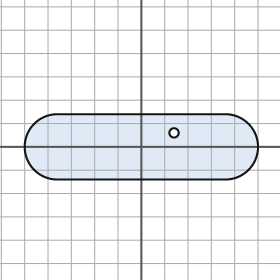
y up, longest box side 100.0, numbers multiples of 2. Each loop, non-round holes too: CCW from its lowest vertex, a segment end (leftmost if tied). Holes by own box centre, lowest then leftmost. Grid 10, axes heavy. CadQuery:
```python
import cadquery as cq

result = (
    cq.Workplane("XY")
    .moveTo(-36.0, -14.0)
    .lineTo(36.0, -14.0)
    .threePointArc((50.0, 0.0), (36.0, 14.0))
    .lineTo(-36.0, 14.0)
    .threePointArc((-50.0, 0.0), (-36.0, -14.0))
    .close()
    .moveTo(14.0, 6.0)
    .circle(2.0)
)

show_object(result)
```